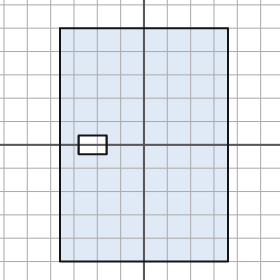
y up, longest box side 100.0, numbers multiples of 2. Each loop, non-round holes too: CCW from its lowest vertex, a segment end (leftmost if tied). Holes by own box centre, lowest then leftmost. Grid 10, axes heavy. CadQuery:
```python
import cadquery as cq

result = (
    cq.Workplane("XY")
    .moveTo(-36.0, -50.0)
    .lineTo(36.0, -50.0)
    .lineTo(36.0, 50.0)
    .lineTo(-36.0, 50.0)
    .close()
    .moveTo(-28.0, -4.0)
    .lineTo(-16.0, -4.0)
    .lineTo(-16.0, 4.0)
    .lineTo(-28.0, 4.0)
    .close()
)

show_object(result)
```